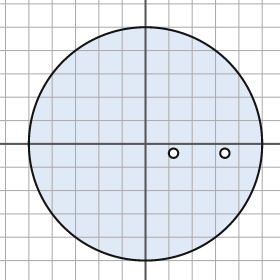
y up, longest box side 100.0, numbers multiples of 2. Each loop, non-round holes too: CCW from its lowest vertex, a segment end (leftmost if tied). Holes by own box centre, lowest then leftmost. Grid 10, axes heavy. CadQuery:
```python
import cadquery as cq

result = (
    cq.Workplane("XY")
    .moveTo(0.0, 0.0)
    .circle(50.0)
    .moveTo(12.0, -4.0)
    .circle(2.0)
    .moveTo(34.0, -4.0)
    .circle(2.0)
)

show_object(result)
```